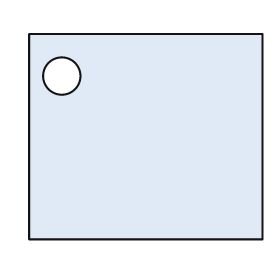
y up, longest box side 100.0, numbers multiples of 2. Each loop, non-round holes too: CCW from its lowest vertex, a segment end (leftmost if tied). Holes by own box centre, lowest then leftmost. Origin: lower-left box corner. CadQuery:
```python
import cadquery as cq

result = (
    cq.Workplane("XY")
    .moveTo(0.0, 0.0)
    .lineTo(100.0, 0.0)
    .lineTo(100.0, 88.0)
    .lineTo(0.0, 88.0)
    .close()
    .moveTo(14.0, 70.0)
    .circle(8.0)
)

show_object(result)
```